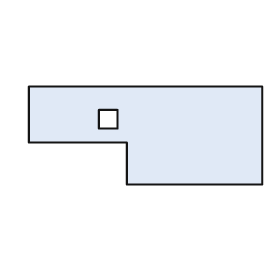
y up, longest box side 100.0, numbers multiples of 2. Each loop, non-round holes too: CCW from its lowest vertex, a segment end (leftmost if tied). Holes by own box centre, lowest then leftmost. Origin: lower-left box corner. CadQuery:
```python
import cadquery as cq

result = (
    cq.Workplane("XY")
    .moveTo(42.0, 0.0)
    .lineTo(100.0, 0.0)
    .lineTo(100.0, 42.0)
    .lineTo(0.0, 42.0)
    .lineTo(0.0, 18.0)
    .lineTo(42.0, 18.0)
    .close()
    .moveTo(30.0, 24.0)
    .lineTo(38.0, 24.0)
    .lineTo(38.0, 32.0)
    .lineTo(30.0, 32.0)
    .close()
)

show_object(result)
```